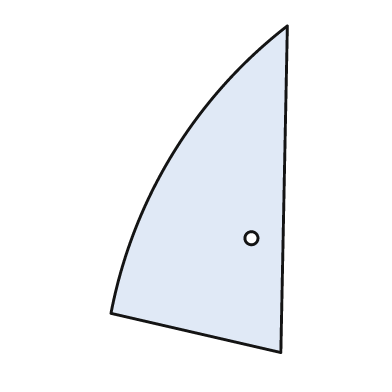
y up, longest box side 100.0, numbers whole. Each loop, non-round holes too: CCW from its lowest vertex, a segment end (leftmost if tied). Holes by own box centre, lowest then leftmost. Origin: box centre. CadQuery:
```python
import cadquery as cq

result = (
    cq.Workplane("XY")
    .moveTo(25.0, -50.0)
    .lineTo(27.0, 50.0)
    .threePointArc((-8.0, 11.0), (-27.0, -38.0))
    .close()
    .moveTo(16.0, -15.0)
    .circle(2.0)
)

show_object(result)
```